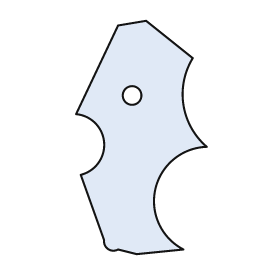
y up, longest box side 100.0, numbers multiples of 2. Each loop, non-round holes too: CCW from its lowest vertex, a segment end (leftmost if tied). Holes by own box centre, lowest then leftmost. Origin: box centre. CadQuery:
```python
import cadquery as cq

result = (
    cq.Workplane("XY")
    .moveTo(-2.0, -50.0)
    .lineTo(18.0, -48.0)
    .threePointArc((6.0, -22.0), (28.0, -4.0))
    .threePointArc((18.0, 14.0), (22.0, 34.0))
    .lineTo(2.0, 50.0)
    .lineTo(-10.0, 48.0)
    .lineTo(-28.0, 10.0)
    .threePointArc((-16.0, -2.0), (-26.0, -16.0))
    .lineTo(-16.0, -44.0)
    .threePointArc((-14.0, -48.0), (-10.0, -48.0))
    .close()
    .moveTo(-4.0, 18.0)
    .circle(4.0)
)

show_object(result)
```